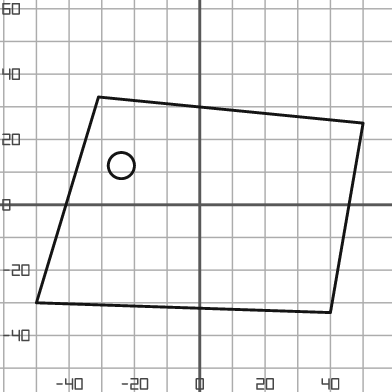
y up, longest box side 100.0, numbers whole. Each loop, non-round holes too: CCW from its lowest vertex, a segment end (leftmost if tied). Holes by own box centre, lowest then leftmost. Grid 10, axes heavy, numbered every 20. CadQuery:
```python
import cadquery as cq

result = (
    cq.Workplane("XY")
    .moveTo(40.0, -33.0)
    .lineTo(50.0, 25.0)
    .lineTo(-31.0, 33.0)
    .lineTo(-50.0, -30.0)
    .close()
    .moveTo(-24.0, 12.0)
    .circle(4.0)
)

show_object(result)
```